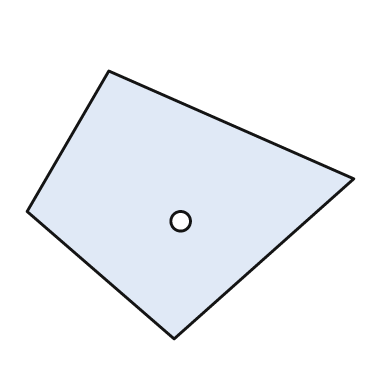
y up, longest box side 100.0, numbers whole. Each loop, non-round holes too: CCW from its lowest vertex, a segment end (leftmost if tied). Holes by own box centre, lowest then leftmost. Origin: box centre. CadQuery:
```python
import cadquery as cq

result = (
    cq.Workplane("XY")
    .moveTo(-5.0, -41.0)
    .lineTo(50.0, 8.0)
    .lineTo(-25.0, 41.0)
    .lineTo(-50.0, -2.0)
    .close()
    .moveTo(-3.0, -5.0)
    .circle(3.0)
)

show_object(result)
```